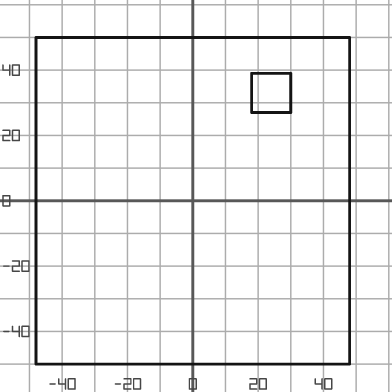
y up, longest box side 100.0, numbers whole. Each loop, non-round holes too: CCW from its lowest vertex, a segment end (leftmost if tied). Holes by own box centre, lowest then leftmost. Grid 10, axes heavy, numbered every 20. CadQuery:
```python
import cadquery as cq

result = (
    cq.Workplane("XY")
    .moveTo(-48.0, -50.0)
    .lineTo(48.0, -50.0)
    .lineTo(48.0, 50.0)
    .lineTo(-48.0, 50.0)
    .close()
    .moveTo(18.0, 27.0)
    .lineTo(30.0, 27.0)
    .lineTo(30.0, 39.0)
    .lineTo(18.0, 39.0)
    .close()
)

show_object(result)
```